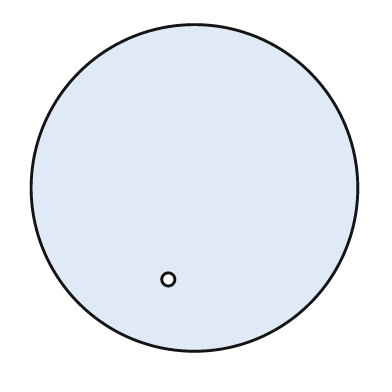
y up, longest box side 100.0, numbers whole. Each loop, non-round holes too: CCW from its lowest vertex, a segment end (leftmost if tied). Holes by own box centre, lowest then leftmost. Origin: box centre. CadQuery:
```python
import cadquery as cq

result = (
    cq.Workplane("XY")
    .moveTo(0.0, 0.0)
    .circle(50.0)
    .moveTo(-8.0, -28.0)
    .circle(2.0)
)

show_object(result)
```